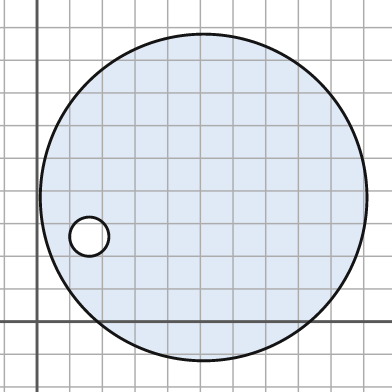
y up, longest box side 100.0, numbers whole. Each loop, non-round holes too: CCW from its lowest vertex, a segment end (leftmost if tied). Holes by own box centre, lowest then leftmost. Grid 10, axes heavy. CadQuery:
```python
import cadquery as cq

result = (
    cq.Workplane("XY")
    .moveTo(51.0, 38.0)
    .circle(50.0)
    .moveTo(16.0, 26.0)
    .circle(6.0)
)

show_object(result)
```